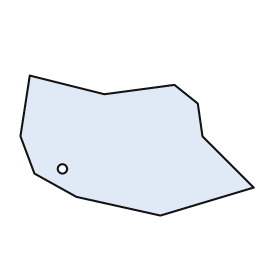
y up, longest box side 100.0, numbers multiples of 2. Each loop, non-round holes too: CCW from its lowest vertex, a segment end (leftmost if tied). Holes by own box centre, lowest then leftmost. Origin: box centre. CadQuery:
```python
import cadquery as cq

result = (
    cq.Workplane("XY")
    .moveTo(10.0, -30.0)
    .lineTo(50.0, -18.0)
    .lineTo(28.0, 4.0)
    .lineTo(26.0, 18.0)
    .lineTo(16.0, 26.0)
    .lineTo(-14.0, 22.0)
    .lineTo(-46.0, 30.0)
    .lineTo(-50.0, 4.0)
    .lineTo(-44.0, -12.0)
    .lineTo(-26.0, -22.0)
    .close()
    .moveTo(-32.0, -10.0)
    .circle(2.0)
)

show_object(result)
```